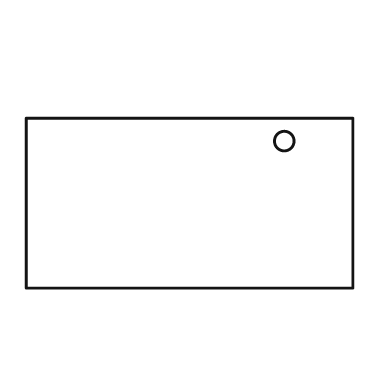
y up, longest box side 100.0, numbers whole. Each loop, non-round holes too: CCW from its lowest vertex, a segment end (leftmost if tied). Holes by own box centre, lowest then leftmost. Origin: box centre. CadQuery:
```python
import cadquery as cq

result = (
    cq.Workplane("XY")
    .moveTo(-50.0, -26.0)
    .lineTo(50.0, -26.0)
    .lineTo(50.0, 26.0)
    .lineTo(-50.0, 26.0)
    .close()
    .moveTo(29.0, 19.0)
    .circle(3.0)
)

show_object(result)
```